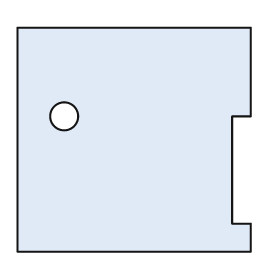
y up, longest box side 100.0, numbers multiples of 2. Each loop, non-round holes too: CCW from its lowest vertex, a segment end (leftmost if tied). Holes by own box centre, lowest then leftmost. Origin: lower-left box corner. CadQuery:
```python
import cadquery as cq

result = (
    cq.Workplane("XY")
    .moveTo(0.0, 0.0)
    .lineTo(100.0, 0.0)
    .lineTo(100.0, 12.0)
    .lineTo(92.0, 12.0)
    .lineTo(92.0, 58.0)
    .lineTo(100.0, 58.0)
    .lineTo(100.0, 96.0)
    .lineTo(0.0, 96.0)
    .close()
    .moveTo(20.0, 58.0)
    .circle(6.0)
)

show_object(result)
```